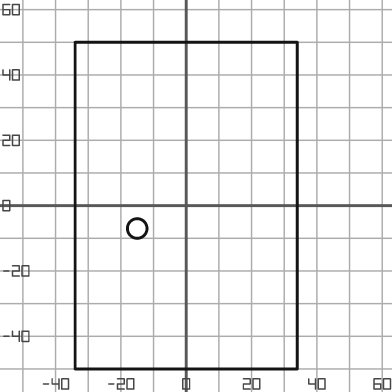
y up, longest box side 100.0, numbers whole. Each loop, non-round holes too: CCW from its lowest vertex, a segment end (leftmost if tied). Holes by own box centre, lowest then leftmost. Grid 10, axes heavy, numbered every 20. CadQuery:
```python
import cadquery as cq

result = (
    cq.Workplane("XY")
    .moveTo(-34.0, -50.0)
    .lineTo(34.0, -50.0)
    .lineTo(34.0, 50.0)
    .lineTo(-34.0, 50.0)
    .close()
    .moveTo(-15.0, -7.0)
    .circle(3.0)
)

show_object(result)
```